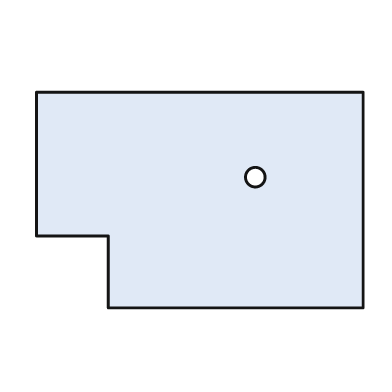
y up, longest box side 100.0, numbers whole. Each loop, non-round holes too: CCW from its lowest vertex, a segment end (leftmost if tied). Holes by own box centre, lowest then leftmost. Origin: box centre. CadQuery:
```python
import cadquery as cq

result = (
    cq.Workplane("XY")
    .moveTo(-28.0, -33.0)
    .lineTo(50.0, -33.0)
    .lineTo(50.0, 33.0)
    .lineTo(-50.0, 33.0)
    .lineTo(-50.0, -11.0)
    .lineTo(-28.0, -11.0)
    .close()
    .moveTo(17.0, 7.0)
    .circle(3.0)
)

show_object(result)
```